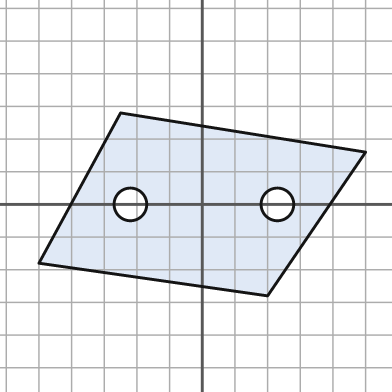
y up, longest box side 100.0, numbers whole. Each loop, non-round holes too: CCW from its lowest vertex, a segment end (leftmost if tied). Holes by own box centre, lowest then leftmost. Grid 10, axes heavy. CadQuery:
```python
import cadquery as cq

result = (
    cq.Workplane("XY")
    .moveTo(20.0, -28.0)
    .lineTo(50.0, 16.0)
    .lineTo(-25.0, 28.0)
    .lineTo(-50.0, -18.0)
    .close()
    .moveTo(-22.0, 0.0)
    .circle(5.0)
    .moveTo(23.0, 0.0)
    .circle(5.0)
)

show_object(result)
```